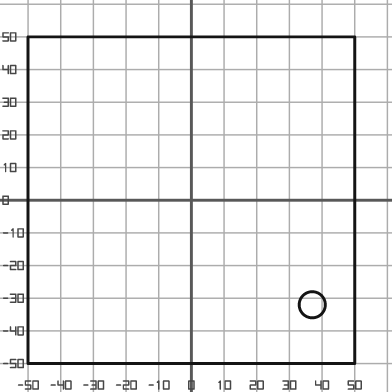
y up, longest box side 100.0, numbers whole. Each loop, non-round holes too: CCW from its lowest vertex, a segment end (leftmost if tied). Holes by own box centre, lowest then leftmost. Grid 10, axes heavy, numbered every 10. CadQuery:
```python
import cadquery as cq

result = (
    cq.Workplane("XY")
    .moveTo(-50.0, -50.0)
    .lineTo(50.0, -50.0)
    .lineTo(50.0, 50.0)
    .lineTo(-50.0, 50.0)
    .close()
    .moveTo(37.0, -32.0)
    .circle(4.0)
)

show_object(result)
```